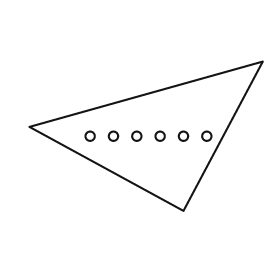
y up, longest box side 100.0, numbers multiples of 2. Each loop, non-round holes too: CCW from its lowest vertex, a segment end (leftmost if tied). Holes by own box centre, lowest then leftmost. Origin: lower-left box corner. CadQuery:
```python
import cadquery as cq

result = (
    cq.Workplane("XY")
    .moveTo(66.0, 0.0)
    .lineTo(100.0, 64.0)
    .lineTo(0.0, 36.0)
    .close()
    .moveTo(26.0, 32.0)
    .circle(2.0)
    .moveTo(36.0, 32.0)
    .circle(2.0)
    .moveTo(46.0, 32.0)
    .circle(2.0)
    .moveTo(56.0, 32.0)
    .circle(2.0)
    .moveTo(66.0, 32.0)
    .circle(2.0)
    .moveTo(76.0, 32.0)
    .circle(2.0)
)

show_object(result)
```